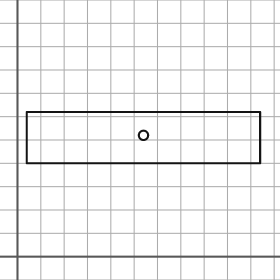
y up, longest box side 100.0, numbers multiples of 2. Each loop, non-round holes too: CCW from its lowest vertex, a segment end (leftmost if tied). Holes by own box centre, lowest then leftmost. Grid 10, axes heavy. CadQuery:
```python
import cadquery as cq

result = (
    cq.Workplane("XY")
    .moveTo(4.0, 40.0)
    .lineTo(104.0, 40.0)
    .lineTo(104.0, 62.0)
    .lineTo(4.0, 62.0)
    .close()
    .moveTo(54.0, 52.0)
    .circle(2.0)
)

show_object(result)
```